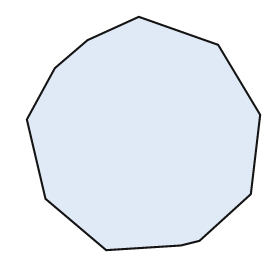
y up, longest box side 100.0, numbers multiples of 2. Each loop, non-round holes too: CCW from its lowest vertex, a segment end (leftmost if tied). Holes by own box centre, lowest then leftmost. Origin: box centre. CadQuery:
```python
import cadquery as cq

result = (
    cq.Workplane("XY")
    .moveTo(-16.0, -50.0)
    .lineTo(16.0, -48.0)
    .lineTo(24.0, -46.0)
    .lineTo(46.0, -26.0)
    .lineTo(50.0, 8.0)
    .lineTo(32.0, 38.0)
    .lineTo(-2.0, 50.0)
    .lineTo(-24.0, 40.0)
    .lineTo(-38.0, 28.0)
    .lineTo(-50.0, 6.0)
    .lineTo(-42.0, -28.0)
    .close()
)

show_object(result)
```